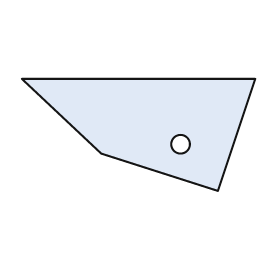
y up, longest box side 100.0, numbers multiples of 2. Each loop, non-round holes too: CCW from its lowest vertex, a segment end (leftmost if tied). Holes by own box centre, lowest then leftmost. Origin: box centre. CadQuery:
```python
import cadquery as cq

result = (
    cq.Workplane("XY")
    .moveTo(34.0, -24.0)
    .lineTo(50.0, 24.0)
    .lineTo(-50.0, 24.0)
    .lineTo(-16.0, -8.0)
    .close()
    .moveTo(18.0, -4.0)
    .circle(4.0)
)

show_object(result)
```